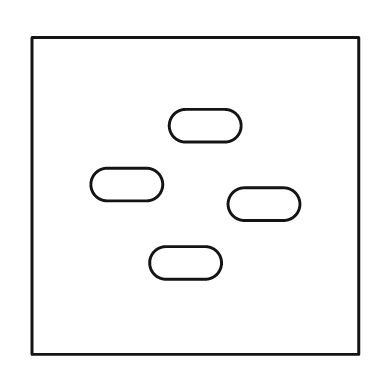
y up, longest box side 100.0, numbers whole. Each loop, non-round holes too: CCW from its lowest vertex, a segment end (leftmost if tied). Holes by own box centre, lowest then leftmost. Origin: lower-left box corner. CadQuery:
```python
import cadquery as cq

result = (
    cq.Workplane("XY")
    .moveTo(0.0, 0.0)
    .lineTo(100.0, 0.0)
    .lineTo(100.0, 97.0)
    .lineTo(0.0, 97.0)
    .close()
    .moveTo(41.0, 23.0)
    .lineTo(53.0, 23.0)
    .threePointArc((58.0, 28.0), (53.0, 33.0))
    .lineTo(41.0, 33.0)
    .threePointArc((36.0, 28.0), (41.0, 23.0))
    .close()
    .moveTo(65.0, 41.0)
    .lineTo(77.0, 41.0)
    .threePointArc((82.0, 46.0), (77.0, 51.0))
    .lineTo(65.0, 51.0)
    .threePointArc((60.0, 46.0), (65.0, 41.0))
    .close()
    .moveTo(23.0, 47.0)
    .lineTo(35.0, 47.0)
    .threePointArc((40.0, 52.0), (35.0, 57.0))
    .lineTo(23.0, 57.0)
    .threePointArc((18.0, 52.0), (23.0, 47.0))
    .close()
    .moveTo(47.0, 65.0)
    .lineTo(59.0, 65.0)
    .threePointArc((64.0, 70.0), (59.0, 75.0))
    .lineTo(47.0, 75.0)
    .threePointArc((42.0, 70.0), (47.0, 65.0))
    .close()
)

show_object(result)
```